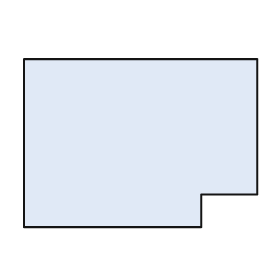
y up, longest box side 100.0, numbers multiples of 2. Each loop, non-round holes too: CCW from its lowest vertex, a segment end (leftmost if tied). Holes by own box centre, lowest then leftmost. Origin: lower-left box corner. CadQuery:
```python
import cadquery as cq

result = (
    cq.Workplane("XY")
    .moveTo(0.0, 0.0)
    .lineTo(76.0, 0.0)
    .lineTo(76.0, 14.0)
    .lineTo(100.0, 14.0)
    .lineTo(100.0, 72.0)
    .lineTo(0.0, 72.0)
    .close()
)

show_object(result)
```